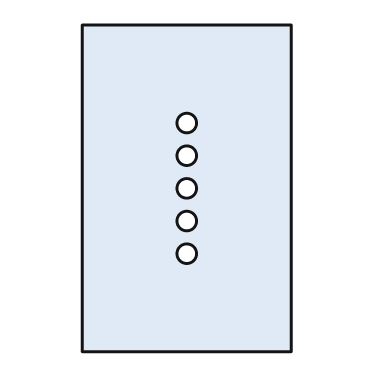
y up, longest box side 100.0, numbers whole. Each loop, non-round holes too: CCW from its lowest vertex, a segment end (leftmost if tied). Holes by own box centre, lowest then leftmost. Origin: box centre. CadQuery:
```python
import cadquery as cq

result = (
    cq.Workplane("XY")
    .moveTo(-32.0, -50.0)
    .lineTo(32.0, -50.0)
    .lineTo(32.0, 50.0)
    .lineTo(-32.0, 50.0)
    .close()
    .moveTo(0.0, -20.0)
    .circle(3.0)
    .moveTo(0.0, -10.0)
    .circle(3.0)
    .moveTo(0.0, 0.0)
    .circle(3.0)
    .moveTo(0.0, 10.0)
    .circle(3.0)
    .moveTo(0.0, 20.0)
    .circle(3.0)
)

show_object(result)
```